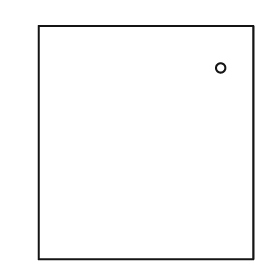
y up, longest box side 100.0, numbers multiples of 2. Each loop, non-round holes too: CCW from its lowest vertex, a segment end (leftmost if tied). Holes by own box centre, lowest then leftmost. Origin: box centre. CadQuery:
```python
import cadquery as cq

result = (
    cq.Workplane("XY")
    .moveTo(-46.0, -50.0)
    .lineTo(46.0, -50.0)
    .lineTo(46.0, 50.0)
    .lineTo(-46.0, 50.0)
    .close()
    .moveTo(32.0, 32.0)
    .circle(2.0)
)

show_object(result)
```